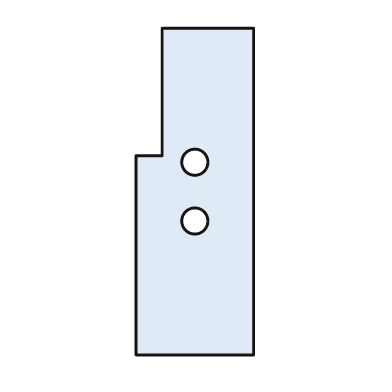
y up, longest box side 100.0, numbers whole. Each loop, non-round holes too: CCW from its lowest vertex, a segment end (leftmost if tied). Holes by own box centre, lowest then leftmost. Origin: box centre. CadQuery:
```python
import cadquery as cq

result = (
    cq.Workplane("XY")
    .moveTo(-18.0, -50.0)
    .lineTo(18.0, -50.0)
    .lineTo(18.0, 50.0)
    .lineTo(-10.0, 50.0)
    .lineTo(-10.0, 11.0)
    .lineTo(-18.0, 11.0)
    .close()
    .moveTo(0.0, -9.0)
    .circle(4.0)
    .moveTo(0.0, 9.0)
    .circle(4.0)
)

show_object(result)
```